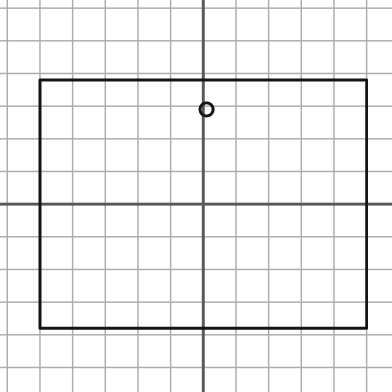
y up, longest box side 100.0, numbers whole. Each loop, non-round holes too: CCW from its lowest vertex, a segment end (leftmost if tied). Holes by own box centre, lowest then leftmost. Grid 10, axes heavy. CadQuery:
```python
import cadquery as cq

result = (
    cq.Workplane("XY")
    .moveTo(-50.0, -38.0)
    .lineTo(50.0, -38.0)
    .lineTo(50.0, 38.0)
    .lineTo(-50.0, 38.0)
    .close()
    .moveTo(1.0, 29.0)
    .circle(2.0)
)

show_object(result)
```